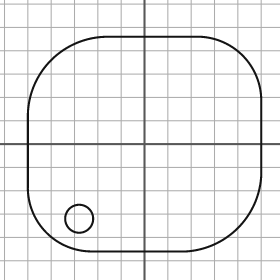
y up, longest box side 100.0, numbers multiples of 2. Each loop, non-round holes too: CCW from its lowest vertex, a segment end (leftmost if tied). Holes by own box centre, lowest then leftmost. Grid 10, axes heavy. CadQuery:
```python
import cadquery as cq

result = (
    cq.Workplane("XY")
    .moveTo(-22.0, -46.0)
    .lineTo(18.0, -46.0)
    .threePointArc((40.0, -36.0), (50.0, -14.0))
    .lineTo(50.0, 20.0)
    .threePointArc((42.0, 38.0), (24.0, 46.0))
    .lineTo(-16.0, 46.0)
    .threePointArc((-40.0, 36.0), (-50.0, 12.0))
    .lineTo(-50.0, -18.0)
    .threePointArc((-42.0, -38.0), (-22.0, -46.0))
    .close()
    .moveTo(-28.0, -32.0)
    .circle(6.0)
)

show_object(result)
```